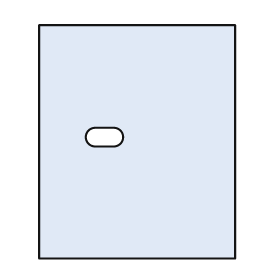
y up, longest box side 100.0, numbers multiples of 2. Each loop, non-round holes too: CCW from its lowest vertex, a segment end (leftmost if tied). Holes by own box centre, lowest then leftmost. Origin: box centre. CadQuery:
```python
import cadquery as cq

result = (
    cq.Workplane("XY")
    .moveTo(-42.0, -50.0)
    .lineTo(42.0, -50.0)
    .lineTo(42.0, 50.0)
    .lineTo(-42.0, 50.0)
    .close()
    .moveTo(-18.0, -2.0)
    .lineTo(-10.0, -2.0)
    .threePointArc((-6.0, 2.0), (-10.0, 6.0))
    .lineTo(-18.0, 6.0)
    .threePointArc((-22.0, 2.0), (-18.0, -2.0))
    .close()
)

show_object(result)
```